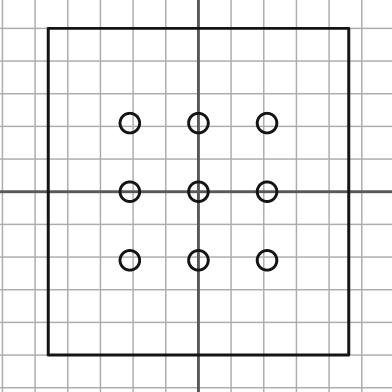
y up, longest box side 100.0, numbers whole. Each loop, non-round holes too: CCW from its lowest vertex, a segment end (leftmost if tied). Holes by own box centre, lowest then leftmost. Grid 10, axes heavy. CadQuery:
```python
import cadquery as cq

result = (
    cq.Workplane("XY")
    .moveTo(-46.0, -50.0)
    .lineTo(46.0, -50.0)
    .lineTo(46.0, 50.0)
    .lineTo(-46.0, 50.0)
    .close()
    .moveTo(-21.0, -21.0)
    .circle(3.0)
    .moveTo(0.0, -21.0)
    .circle(3.0)
    .moveTo(21.0, -21.0)
    .circle(3.0)
    .moveTo(-21.0, 0.0)
    .circle(3.0)
    .moveTo(0.0, 0.0)
    .circle(3.0)
    .moveTo(21.0, 0.0)
    .circle(3.0)
    .moveTo(-21.0, 21.0)
    .circle(3.0)
    .moveTo(0.0, 21.0)
    .circle(3.0)
    .moveTo(21.0, 21.0)
    .circle(3.0)
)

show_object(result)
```